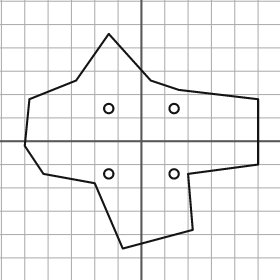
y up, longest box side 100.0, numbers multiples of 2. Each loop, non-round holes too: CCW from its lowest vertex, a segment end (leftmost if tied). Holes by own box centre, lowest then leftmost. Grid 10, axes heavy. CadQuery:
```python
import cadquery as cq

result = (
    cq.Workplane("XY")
    .moveTo(-8.0, -46.0)
    .lineTo(22.0, -38.0)
    .lineTo(20.0, -14.0)
    .lineTo(50.0, -10.0)
    .lineTo(50.0, 18.0)
    .lineTo(16.0, 22.0)
    .lineTo(4.0, 26.0)
    .lineTo(-14.0, 46.0)
    .lineTo(-28.0, 26.0)
    .lineTo(-48.0, 18.0)
    .lineTo(-50.0, -2.0)
    .lineTo(-42.0, -14.0)
    .lineTo(-20.0, -18.0)
    .close()
    .moveTo(-14.0, -14.0)
    .circle(2.0)
    .moveTo(14.0, -14.0)
    .circle(2.0)
    .moveTo(-14.0, 14.0)
    .circle(2.0)
    .moveTo(14.0, 14.0)
    .circle(2.0)
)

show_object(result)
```